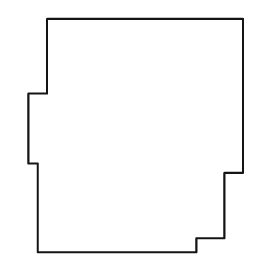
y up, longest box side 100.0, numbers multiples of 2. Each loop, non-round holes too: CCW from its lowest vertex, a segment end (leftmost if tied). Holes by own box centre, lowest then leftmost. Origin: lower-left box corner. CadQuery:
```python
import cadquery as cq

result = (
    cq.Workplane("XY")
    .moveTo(4.0, 0.0)
    .lineTo(72.0, 0.0)
    .lineTo(72.0, 6.0)
    .lineTo(84.0, 6.0)
    .lineTo(84.0, 34.0)
    .lineTo(92.0, 34.0)
    .lineTo(92.0, 100.0)
    .lineTo(8.0, 100.0)
    .lineTo(8.0, 68.0)
    .lineTo(0.0, 68.0)
    .lineTo(0.0, 38.0)
    .lineTo(4.0, 38.0)
    .close()
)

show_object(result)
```